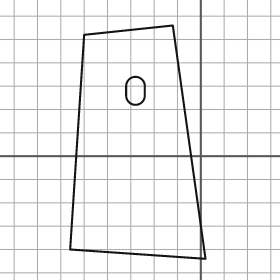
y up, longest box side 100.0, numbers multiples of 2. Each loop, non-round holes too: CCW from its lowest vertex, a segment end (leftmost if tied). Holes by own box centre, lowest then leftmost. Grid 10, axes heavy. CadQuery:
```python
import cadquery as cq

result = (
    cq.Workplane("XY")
    .moveTo(2.0, -44.0)
    .lineTo(-12.0, 56.0)
    .lineTo(-50.0, 52.0)
    .lineTo(-56.0, -40.0)
    .close()
    .moveTo(-32.0, 26.0)
    .threePointArc((-28.0, 22.0), (-24.0, 26.0))
    .lineTo(-24.0, 30.0)
    .threePointArc((-28.0, 34.0), (-32.0, 30.0))
    .close()
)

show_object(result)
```